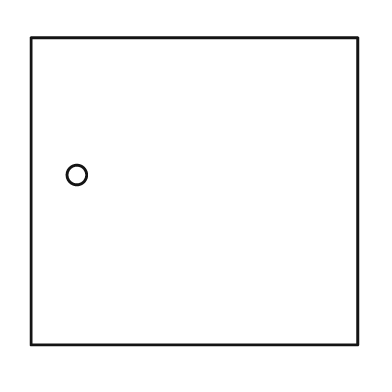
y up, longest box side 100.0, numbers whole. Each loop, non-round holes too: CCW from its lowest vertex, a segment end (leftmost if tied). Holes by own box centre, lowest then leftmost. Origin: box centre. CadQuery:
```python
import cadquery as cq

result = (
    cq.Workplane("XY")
    .moveTo(-50.0, -47.0)
    .lineTo(50.0, -47.0)
    .lineTo(50.0, 47.0)
    .lineTo(-50.0, 47.0)
    .close()
    .moveTo(-36.0, 5.0)
    .circle(3.0)
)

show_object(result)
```